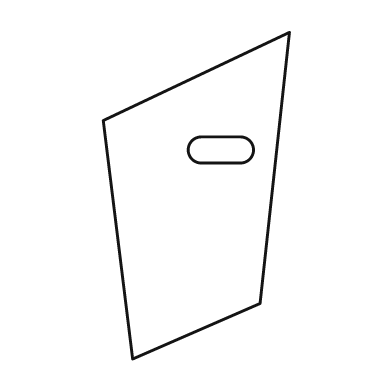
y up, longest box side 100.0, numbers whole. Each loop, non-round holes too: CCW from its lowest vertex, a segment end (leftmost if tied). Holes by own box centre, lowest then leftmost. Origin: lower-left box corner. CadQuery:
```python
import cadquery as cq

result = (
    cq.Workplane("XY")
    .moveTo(9.0, 0.0)
    .lineTo(48.0, 17.0)
    .lineTo(57.0, 100.0)
    .lineTo(0.0, 73.0)
    .close()
    .moveTo(30.0, 60.0)
    .lineTo(42.0, 60.0)
    .threePointArc((46.0, 64.0), (42.0, 68.0))
    .lineTo(30.0, 68.0)
    .threePointArc((26.0, 64.0), (30.0, 60.0))
    .close()
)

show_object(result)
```